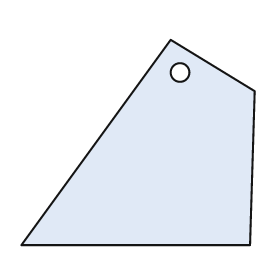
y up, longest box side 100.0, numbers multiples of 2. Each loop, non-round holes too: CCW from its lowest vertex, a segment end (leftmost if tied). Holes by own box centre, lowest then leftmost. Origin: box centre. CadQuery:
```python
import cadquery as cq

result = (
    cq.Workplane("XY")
    .moveTo(-50.0, -44.0)
    .lineTo(48.0, -44.0)
    .lineTo(50.0, 22.0)
    .lineTo(14.0, 44.0)
    .close()
    .moveTo(18.0, 30.0)
    .circle(4.0)
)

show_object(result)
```